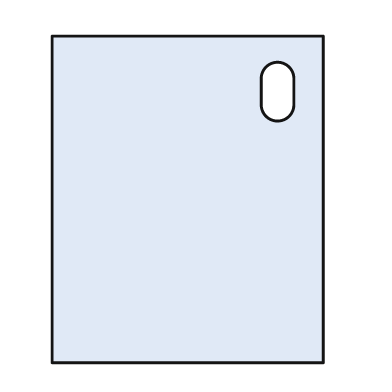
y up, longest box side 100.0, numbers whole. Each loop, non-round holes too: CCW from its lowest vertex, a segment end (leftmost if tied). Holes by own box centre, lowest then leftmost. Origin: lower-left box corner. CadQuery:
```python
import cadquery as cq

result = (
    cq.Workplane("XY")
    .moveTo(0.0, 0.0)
    .lineTo(83.0, 0.0)
    .lineTo(83.0, 100.0)
    .lineTo(0.0, 100.0)
    .close()
    .moveTo(64.0, 79.0)
    .threePointArc((69.0, 74.0), (74.0, 79.0))
    .lineTo(74.0, 87.0)
    .threePointArc((69.0, 92.0), (64.0, 87.0))
    .close()
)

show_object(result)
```